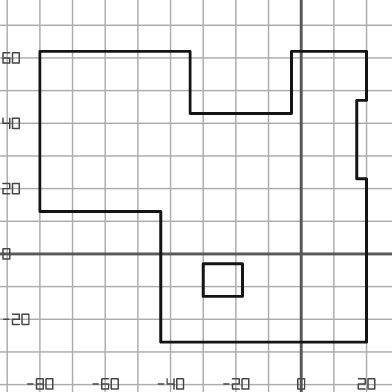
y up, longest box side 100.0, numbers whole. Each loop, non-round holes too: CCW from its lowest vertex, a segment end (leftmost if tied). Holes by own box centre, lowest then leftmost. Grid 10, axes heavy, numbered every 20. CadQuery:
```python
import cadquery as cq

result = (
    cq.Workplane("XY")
    .moveTo(-43.0, -27.0)
    .lineTo(20.0, -27.0)
    .lineTo(20.0, 23.0)
    .lineTo(17.0, 23.0)
    .lineTo(17.0, 47.0)
    .lineTo(20.0, 47.0)
    .lineTo(20.0, 62.0)
    .lineTo(-3.0, 62.0)
    .lineTo(-3.0, 43.0)
    .lineTo(-34.0, 43.0)
    .lineTo(-34.0, 62.0)
    .lineTo(-80.0, 62.0)
    .lineTo(-80.0, 13.0)
    .lineTo(-43.0, 13.0)
    .close()
    .moveTo(-30.0, -13.0)
    .lineTo(-18.0, -13.0)
    .lineTo(-18.0, -3.0)
    .lineTo(-30.0, -3.0)
    .close()
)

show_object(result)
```